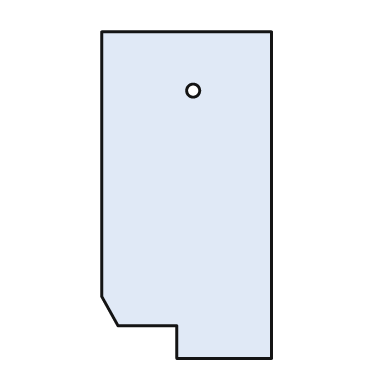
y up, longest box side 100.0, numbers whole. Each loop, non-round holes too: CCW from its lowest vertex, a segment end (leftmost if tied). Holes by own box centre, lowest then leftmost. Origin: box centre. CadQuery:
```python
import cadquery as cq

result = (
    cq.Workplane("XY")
    .moveTo(-3.0, -50.0)
    .lineTo(26.0, -50.0)
    .lineTo(26.0, 50.0)
    .lineTo(-26.0, 50.0)
    .lineTo(-26.0, -31.0)
    .lineTo(-21.0, -40.0)
    .lineTo(-3.0, -40.0)
    .close()
    .moveTo(2.0, 32.0)
    .circle(2.0)
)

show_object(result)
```